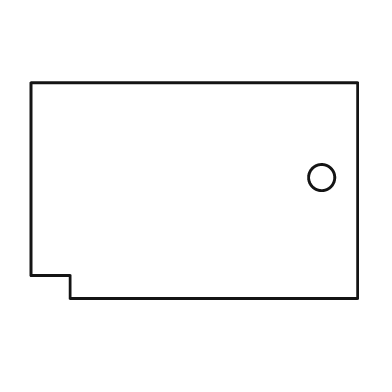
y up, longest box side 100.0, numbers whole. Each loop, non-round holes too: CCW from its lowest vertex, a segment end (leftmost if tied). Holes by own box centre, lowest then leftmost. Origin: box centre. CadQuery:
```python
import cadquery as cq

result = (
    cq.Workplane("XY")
    .moveTo(-38.0, -33.0)
    .lineTo(50.0, -33.0)
    .lineTo(50.0, 33.0)
    .lineTo(-50.0, 33.0)
    .lineTo(-50.0, -26.0)
    .lineTo(-38.0, -26.0)
    .close()
    .moveTo(39.0, 4.0)
    .circle(4.0)
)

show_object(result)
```